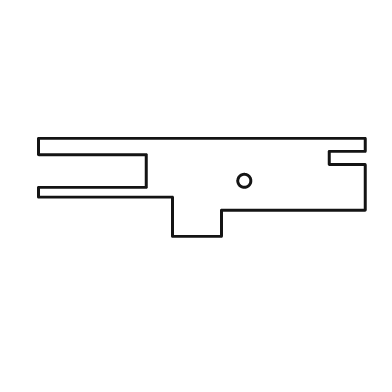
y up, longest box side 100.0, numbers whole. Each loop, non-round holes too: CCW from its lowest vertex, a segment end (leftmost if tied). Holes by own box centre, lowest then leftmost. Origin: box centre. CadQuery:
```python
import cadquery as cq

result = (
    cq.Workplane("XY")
    .moveTo(-9.0, -15.0)
    .lineTo(6.0, -15.0)
    .lineTo(6.0, -7.0)
    .lineTo(50.0, -7.0)
    .lineTo(50.0, 7.0)
    .lineTo(39.0, 7.0)
    .lineTo(39.0, 11.0)
    .lineTo(50.0, 11.0)
    .lineTo(50.0, 15.0)
    .lineTo(-50.0, 15.0)
    .lineTo(-50.0, 10.0)
    .lineTo(-17.0, 10.0)
    .lineTo(-17.0, 0.0)
    .lineTo(-50.0, 0.0)
    .lineTo(-50.0, -3.0)
    .lineTo(-9.0, -3.0)
    .close()
    .moveTo(13.0, 2.0)
    .circle(2.0)
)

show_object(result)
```